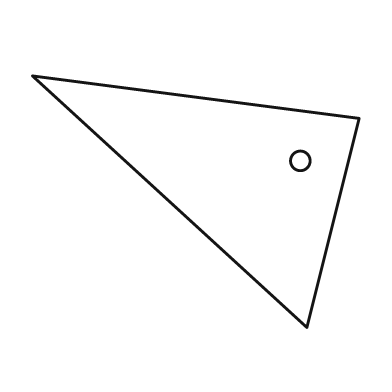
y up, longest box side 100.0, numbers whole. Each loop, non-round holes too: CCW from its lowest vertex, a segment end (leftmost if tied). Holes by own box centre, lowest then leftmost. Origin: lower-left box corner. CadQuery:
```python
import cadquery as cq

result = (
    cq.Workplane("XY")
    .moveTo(84.0, 0.0)
    .lineTo(100.0, 64.0)
    .lineTo(0.0, 77.0)
    .close()
    .moveTo(82.0, 51.0)
    .circle(3.0)
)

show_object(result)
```